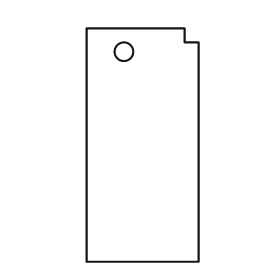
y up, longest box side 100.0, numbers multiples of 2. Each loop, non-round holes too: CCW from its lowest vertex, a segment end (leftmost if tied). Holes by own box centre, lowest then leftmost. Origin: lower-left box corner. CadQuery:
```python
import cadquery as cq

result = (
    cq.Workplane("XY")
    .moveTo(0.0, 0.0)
    .lineTo(48.0, 0.0)
    .lineTo(48.0, 94.0)
    .lineTo(42.0, 94.0)
    .lineTo(42.0, 100.0)
    .lineTo(0.0, 100.0)
    .close()
    .moveTo(16.0, 90.0)
    .circle(4.0)
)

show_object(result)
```